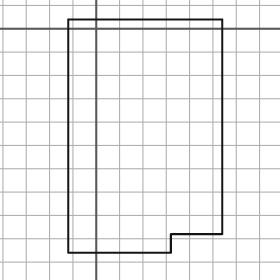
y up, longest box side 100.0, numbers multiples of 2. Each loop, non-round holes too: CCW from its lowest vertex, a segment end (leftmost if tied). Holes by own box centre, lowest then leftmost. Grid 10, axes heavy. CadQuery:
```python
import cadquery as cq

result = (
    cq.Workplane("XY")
    .moveTo(-12.0, -96.0)
    .lineTo(32.0, -96.0)
    .lineTo(32.0, -88.0)
    .lineTo(54.0, -88.0)
    .lineTo(54.0, 4.0)
    .lineTo(-12.0, 4.0)
    .close()
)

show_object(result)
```